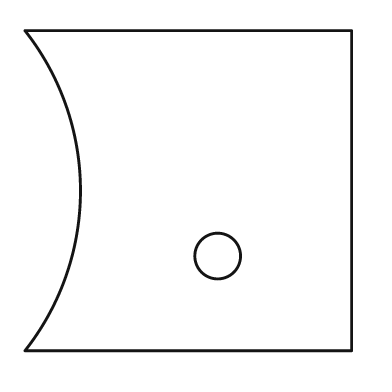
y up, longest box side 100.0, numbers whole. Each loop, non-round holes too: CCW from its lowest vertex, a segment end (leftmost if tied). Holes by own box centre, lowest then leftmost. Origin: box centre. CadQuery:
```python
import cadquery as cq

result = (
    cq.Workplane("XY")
    .moveTo(-50.0, -49.0)
    .lineTo(50.0, -49.0)
    .lineTo(50.0, 49.0)
    .lineTo(-50.0, 49.0)
    .threePointArc((-33.0, 0.0), (-50.0, -49.0))
    .close()
    .moveTo(9.0, -20.0)
    .circle(7.0)
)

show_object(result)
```